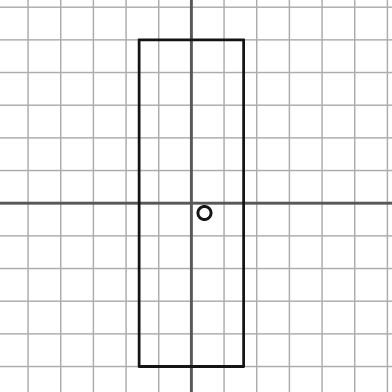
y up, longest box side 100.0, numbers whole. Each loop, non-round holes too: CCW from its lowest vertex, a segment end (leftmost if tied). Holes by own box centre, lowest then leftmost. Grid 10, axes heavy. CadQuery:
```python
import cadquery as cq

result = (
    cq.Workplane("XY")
    .moveTo(-16.0, -50.0)
    .lineTo(16.0, -50.0)
    .lineTo(16.0, 50.0)
    .lineTo(-16.0, 50.0)
    .close()
    .moveTo(4.0, -3.0)
    .circle(2.0)
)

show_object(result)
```